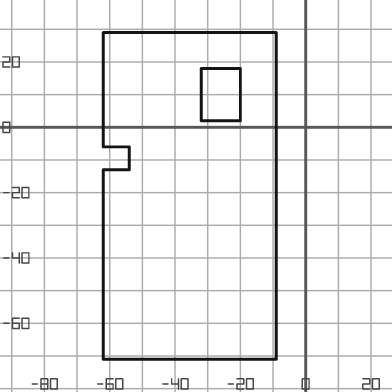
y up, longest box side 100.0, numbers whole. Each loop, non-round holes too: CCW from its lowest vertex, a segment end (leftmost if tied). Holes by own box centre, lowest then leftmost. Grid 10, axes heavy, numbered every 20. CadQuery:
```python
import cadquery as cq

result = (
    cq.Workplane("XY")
    .moveTo(-62.0, -71.0)
    .lineTo(-9.0, -71.0)
    .lineTo(-9.0, 29.0)
    .lineTo(-62.0, 29.0)
    .lineTo(-62.0, -6.0)
    .lineTo(-54.0, -6.0)
    .lineTo(-54.0, -13.0)
    .lineTo(-62.0, -13.0)
    .close()
    .moveTo(-32.0, 2.0)
    .lineTo(-20.0, 2.0)
    .lineTo(-20.0, 18.0)
    .lineTo(-32.0, 18.0)
    .close()
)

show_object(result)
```